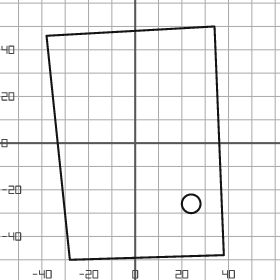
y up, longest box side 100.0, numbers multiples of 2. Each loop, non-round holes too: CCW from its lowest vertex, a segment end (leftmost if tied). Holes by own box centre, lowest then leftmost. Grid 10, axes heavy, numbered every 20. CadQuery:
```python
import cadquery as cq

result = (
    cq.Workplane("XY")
    .moveTo(-28.0, -50.0)
    .lineTo(38.0, -48.0)
    .lineTo(34.0, 50.0)
    .lineTo(-38.0, 46.0)
    .close()
    .moveTo(24.0, -26.0)
    .circle(4.0)
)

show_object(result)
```